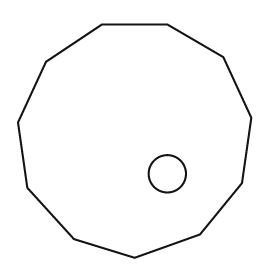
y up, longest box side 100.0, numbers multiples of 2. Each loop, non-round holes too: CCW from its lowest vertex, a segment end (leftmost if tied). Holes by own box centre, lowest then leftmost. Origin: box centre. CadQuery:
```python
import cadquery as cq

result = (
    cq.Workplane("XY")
    .moveTo(0.0, -50.0)
    .lineTo(28.0, -40.0)
    .lineTo(46.0, -18.0)
    .lineTo(50.0, 10.0)
    .lineTo(38.0, 36.0)
    .lineTo(14.0, 50.0)
    .lineTo(-14.0, 50.0)
    .lineTo(-38.0, 34.0)
    .lineTo(-50.0, 8.0)
    .lineTo(-46.0, -20.0)
    .lineTo(-26.0, -42.0)
    .close()
    .moveTo(14.0, -14.0)
    .circle(8.0)
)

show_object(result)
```